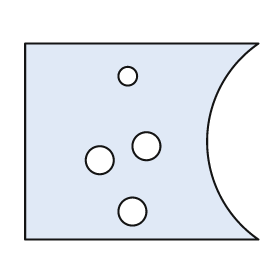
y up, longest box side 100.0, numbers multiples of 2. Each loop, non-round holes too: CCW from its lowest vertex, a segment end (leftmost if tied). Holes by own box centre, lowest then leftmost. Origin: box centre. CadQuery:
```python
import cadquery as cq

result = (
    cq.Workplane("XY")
    .moveTo(-50.0, -42.0)
    .lineTo(50.0, -42.0)
    .threePointArc((28.0, 0.0), (50.0, 42.0))
    .lineTo(-50.0, 42.0)
    .close()
    .moveTo(-4.0, -30.0)
    .circle(6.0)
    .moveTo(-18.0, -8.0)
    .circle(6.0)
    .moveTo(2.0, -2.0)
    .circle(6.0)
    .moveTo(-6.0, 28.0)
    .circle(4.0)
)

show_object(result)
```